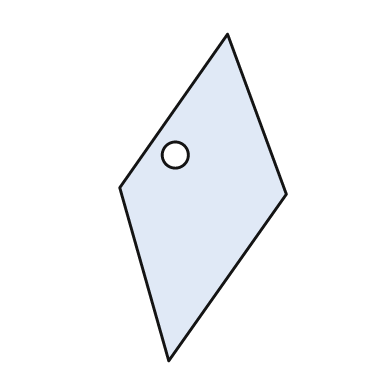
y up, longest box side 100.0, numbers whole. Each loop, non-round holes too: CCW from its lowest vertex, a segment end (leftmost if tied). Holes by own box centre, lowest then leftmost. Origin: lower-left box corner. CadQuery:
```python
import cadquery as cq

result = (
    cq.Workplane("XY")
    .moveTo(15.0, 0.0)
    .lineTo(51.0, 51.0)
    .lineTo(33.0, 100.0)
    .lineTo(0.0, 53.0)
    .close()
    .moveTo(17.0, 63.0)
    .circle(4.0)
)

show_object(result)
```